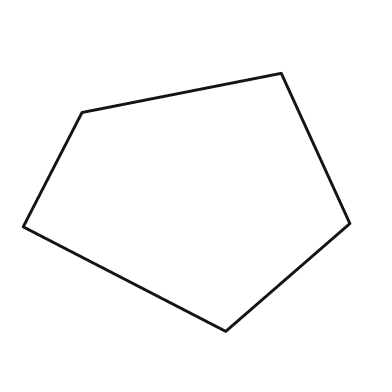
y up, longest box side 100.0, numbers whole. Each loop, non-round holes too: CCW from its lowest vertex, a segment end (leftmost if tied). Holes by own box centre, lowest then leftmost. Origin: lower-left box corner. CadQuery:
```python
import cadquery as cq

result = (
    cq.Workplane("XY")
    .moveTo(62.0, 0.0)
    .lineTo(100.0, 33.0)
    .lineTo(79.0, 79.0)
    .lineTo(18.0, 67.0)
    .lineTo(0.0, 32.0)
    .close()
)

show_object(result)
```